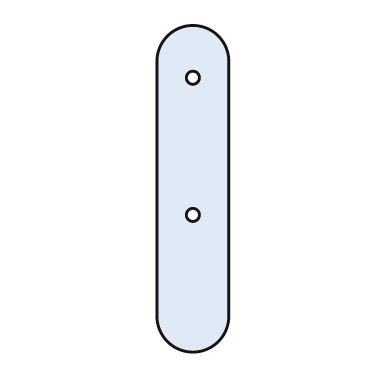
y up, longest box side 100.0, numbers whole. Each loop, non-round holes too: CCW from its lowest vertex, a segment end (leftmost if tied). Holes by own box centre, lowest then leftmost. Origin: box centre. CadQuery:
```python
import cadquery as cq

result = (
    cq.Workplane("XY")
    .moveTo(-11.0, -39.0)
    .threePointArc((0.0, -50.0), (11.0, -39.0))
    .lineTo(11.0, 39.0)
    .threePointArc((0.0, 50.0), (-11.0, 39.0))
    .close()
    .moveTo(0.0, -8.0)
    .circle(2.0)
    .moveTo(0.0, 34.0)
    .circle(2.0)
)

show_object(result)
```